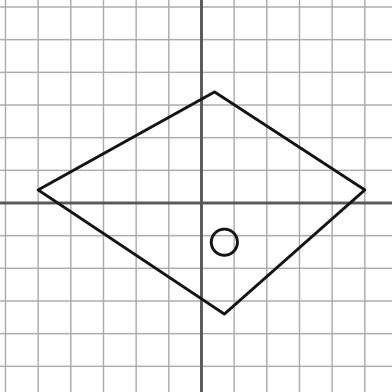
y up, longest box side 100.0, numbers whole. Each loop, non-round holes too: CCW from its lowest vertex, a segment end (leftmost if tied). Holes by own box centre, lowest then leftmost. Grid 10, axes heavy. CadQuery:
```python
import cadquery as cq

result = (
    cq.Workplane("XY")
    .moveTo(7.0, -34.0)
    .lineTo(50.0, 4.0)
    .lineTo(4.0, 34.0)
    .lineTo(-50.0, 4.0)
    .close()
    .moveTo(7.0, -12.0)
    .circle(4.0)
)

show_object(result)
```